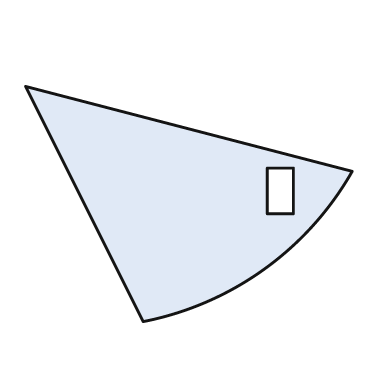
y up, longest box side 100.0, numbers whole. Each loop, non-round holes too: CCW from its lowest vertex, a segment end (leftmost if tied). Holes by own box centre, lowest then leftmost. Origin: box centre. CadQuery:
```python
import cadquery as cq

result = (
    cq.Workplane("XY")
    .moveTo(-14.0, -36.0)
    .threePointArc((23.0, -20.0), (50.0, 10.0))
    .lineTo(-50.0, 36.0)
    .close()
    .moveTo(24.0, -3.0)
    .lineTo(32.0, -3.0)
    .lineTo(32.0, 11.0)
    .lineTo(24.0, 11.0)
    .close()
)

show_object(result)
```